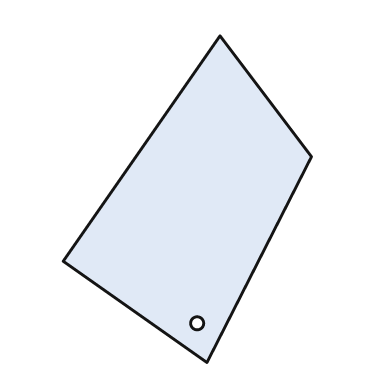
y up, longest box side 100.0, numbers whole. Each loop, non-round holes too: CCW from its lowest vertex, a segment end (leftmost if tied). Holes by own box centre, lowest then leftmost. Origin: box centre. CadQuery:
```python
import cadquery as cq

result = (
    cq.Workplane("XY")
    .moveTo(6.0, -50.0)
    .lineTo(38.0, 13.0)
    .lineTo(10.0, 50.0)
    .lineTo(-38.0, -19.0)
    .close()
    .moveTo(3.0, -38.0)
    .circle(2.0)
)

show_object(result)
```